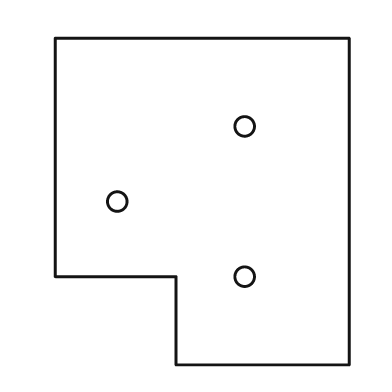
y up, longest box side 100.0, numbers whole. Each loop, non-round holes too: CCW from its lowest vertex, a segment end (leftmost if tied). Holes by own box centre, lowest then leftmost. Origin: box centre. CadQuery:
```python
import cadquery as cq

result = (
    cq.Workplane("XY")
    .moveTo(-8.0, -50.0)
    .lineTo(45.0, -50.0)
    .lineTo(45.0, 50.0)
    .lineTo(-45.0, 50.0)
    .lineTo(-45.0, -23.0)
    .lineTo(-8.0, -23.0)
    .close()
    .moveTo(13.0, -23.0)
    .circle(3.0)
    .moveTo(-26.0, 0.0)
    .circle(3.0)
    .moveTo(13.0, 23.0)
    .circle(3.0)
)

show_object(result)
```